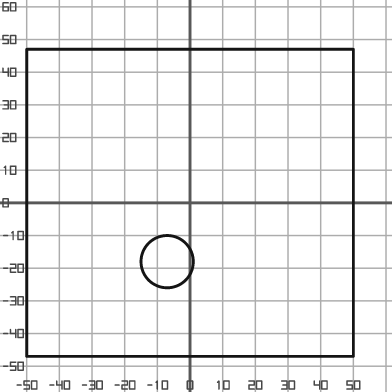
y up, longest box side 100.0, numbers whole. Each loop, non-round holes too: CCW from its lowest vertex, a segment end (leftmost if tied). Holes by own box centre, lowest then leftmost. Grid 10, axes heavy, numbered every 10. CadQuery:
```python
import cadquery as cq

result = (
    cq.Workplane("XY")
    .moveTo(-50.0, -47.0)
    .lineTo(50.0, -47.0)
    .lineTo(50.0, 47.0)
    .lineTo(-50.0, 47.0)
    .close()
    .moveTo(-7.0, -18.0)
    .circle(8.0)
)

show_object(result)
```